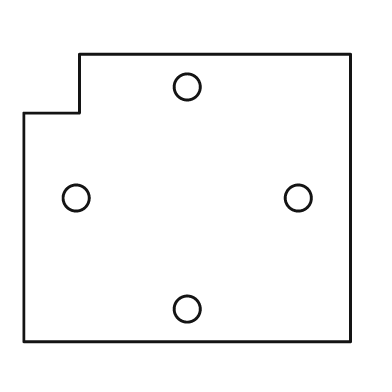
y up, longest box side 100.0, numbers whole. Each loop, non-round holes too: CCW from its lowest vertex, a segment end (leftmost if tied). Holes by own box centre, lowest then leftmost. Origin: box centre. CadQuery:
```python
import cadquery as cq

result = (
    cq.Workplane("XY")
    .moveTo(-50.0, -44.0)
    .lineTo(50.0, -44.0)
    .lineTo(50.0, 44.0)
    .lineTo(-33.0, 44.0)
    .lineTo(-33.0, 26.0)
    .lineTo(-50.0, 26.0)
    .close()
    .moveTo(0.0, -34.0)
    .circle(4.0)
    .moveTo(-34.0, 0.0)
    .circle(4.0)
    .moveTo(34.0, 0.0)
    .circle(4.0)
    .moveTo(0.0, 34.0)
    .circle(4.0)
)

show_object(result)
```